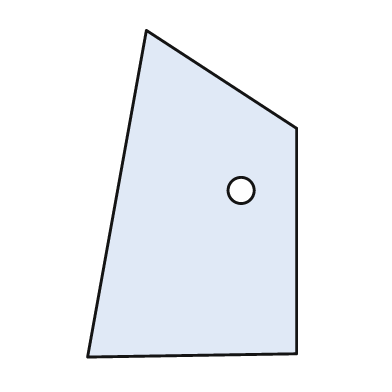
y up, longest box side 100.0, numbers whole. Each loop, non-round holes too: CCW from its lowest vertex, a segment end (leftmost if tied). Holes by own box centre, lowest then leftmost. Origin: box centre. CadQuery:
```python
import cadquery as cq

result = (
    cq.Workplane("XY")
    .moveTo(-32.0, -50.0)
    .lineTo(32.0, -49.0)
    .lineTo(32.0, 20.0)
    .lineTo(-14.0, 50.0)
    .close()
    .moveTo(15.0, 1.0)
    .circle(4.0)
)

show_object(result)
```